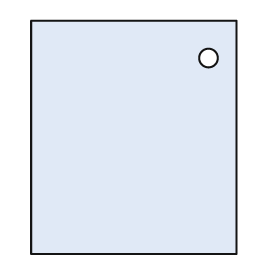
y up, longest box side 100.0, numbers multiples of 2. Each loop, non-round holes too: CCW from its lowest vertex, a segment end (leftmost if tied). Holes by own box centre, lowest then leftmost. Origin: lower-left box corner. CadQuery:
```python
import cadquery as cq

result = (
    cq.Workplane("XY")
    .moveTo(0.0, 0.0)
    .lineTo(88.0, 0.0)
    .lineTo(88.0, 100.0)
    .lineTo(0.0, 100.0)
    .close()
    .moveTo(76.0, 84.0)
    .circle(4.0)
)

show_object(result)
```